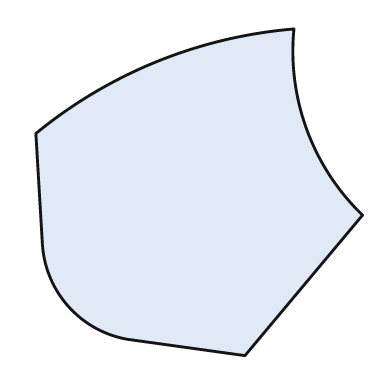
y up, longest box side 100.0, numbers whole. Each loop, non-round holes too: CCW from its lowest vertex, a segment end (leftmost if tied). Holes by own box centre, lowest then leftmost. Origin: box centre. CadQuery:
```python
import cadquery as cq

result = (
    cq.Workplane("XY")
    .moveTo(14.0, -50.0)
    .lineTo(50.0, -7.0)
    .threePointArc((33.0, 19.0), (29.0, 50.0))
    .threePointArc((-13.0, 40.0), (-50.0, 18.0))
    .lineTo(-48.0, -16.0)
    .threePointArc((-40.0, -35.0), (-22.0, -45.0))
    .close()
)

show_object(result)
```